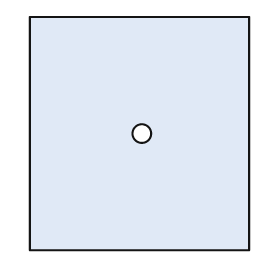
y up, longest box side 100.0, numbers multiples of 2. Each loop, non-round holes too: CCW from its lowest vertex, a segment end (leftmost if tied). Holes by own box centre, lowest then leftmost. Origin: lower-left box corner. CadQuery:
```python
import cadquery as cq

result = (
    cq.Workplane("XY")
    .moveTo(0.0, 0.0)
    .lineTo(94.0, 0.0)
    .lineTo(94.0, 100.0)
    .lineTo(0.0, 100.0)
    .close()
    .moveTo(48.0, 50.0)
    .circle(4.0)
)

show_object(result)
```